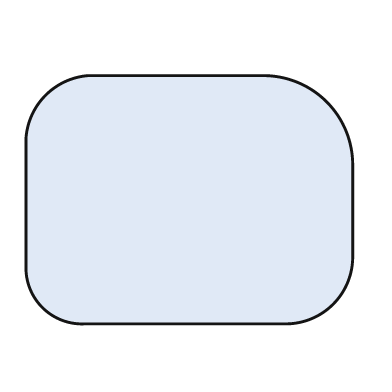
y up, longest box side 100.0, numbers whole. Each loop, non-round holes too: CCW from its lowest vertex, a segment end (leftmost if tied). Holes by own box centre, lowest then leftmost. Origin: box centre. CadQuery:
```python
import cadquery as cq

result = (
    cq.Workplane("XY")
    .moveTo(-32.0, -38.0)
    .lineTo(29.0, -38.0)
    .threePointArc((44.0, -32.0), (50.0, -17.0))
    .lineTo(50.0, 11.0)
    .threePointArc((42.0, 30.0), (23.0, 38.0))
    .lineTo(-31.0, 38.0)
    .threePointArc((-44.0, 32.0), (-50.0, 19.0))
    .lineTo(-50.0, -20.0)
    .threePointArc((-45.0, -33.0), (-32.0, -38.0))
    .close()
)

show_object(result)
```